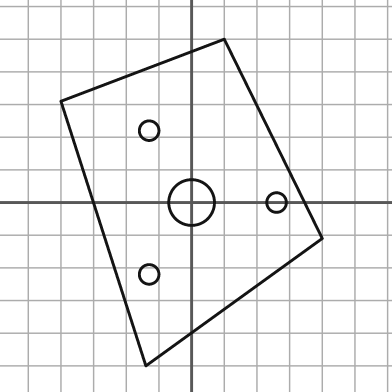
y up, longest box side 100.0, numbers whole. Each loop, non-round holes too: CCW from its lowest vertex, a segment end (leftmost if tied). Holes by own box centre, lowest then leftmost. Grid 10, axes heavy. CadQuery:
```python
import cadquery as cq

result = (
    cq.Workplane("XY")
    .moveTo(-14.0, -50.0)
    .lineTo(40.0, -11.0)
    .lineTo(10.0, 50.0)
    .lineTo(-40.0, 31.0)
    .close()
    .moveTo(-13.0, -22.0)
    .circle(3.0)
    .moveTo(0.0, 0.0)
    .circle(7.0)
    .moveTo(26.0, 0.0)
    .circle(3.0)
    .moveTo(-13.0, 22.0)
    .circle(3.0)
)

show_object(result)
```